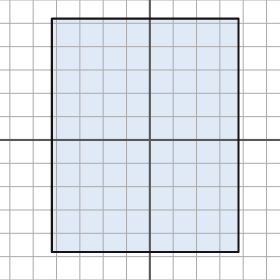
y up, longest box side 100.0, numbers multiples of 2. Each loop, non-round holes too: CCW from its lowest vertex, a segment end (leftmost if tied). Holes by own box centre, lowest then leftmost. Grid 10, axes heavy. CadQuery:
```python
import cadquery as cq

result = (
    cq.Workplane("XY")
    .moveTo(-42.0, -48.0)
    .lineTo(38.0, -48.0)
    .lineTo(38.0, 52.0)
    .lineTo(-42.0, 52.0)
    .close()
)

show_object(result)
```